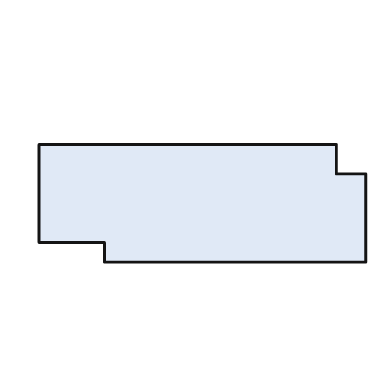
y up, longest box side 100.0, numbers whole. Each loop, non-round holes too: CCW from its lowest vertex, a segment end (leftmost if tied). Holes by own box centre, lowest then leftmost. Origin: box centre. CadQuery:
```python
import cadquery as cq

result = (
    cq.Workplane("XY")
    .moveTo(-30.0, -18.0)
    .lineTo(50.0, -18.0)
    .lineTo(50.0, 9.0)
    .lineTo(41.0, 9.0)
    .lineTo(41.0, 18.0)
    .lineTo(-50.0, 18.0)
    .lineTo(-50.0, -12.0)
    .lineTo(-30.0, -12.0)
    .close()
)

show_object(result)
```